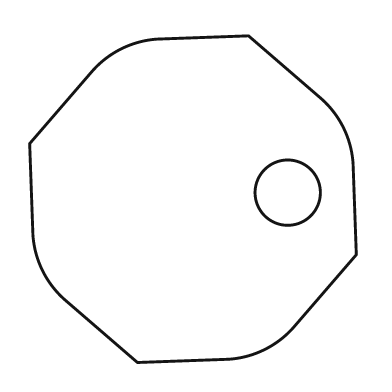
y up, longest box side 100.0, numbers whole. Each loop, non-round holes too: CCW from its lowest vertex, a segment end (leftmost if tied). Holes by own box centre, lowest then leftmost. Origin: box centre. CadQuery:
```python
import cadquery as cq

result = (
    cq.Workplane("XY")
    .moveTo(-17.0, -50.0)
    .lineTo(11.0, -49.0)
    .threePointArc((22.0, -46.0), (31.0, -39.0))
    .lineTo(50.0, -17.0)
    .lineTo(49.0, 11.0)
    .threePointArc((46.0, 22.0), (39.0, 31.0))
    .lineTo(17.0, 50.0)
    .lineTo(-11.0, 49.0)
    .threePointArc((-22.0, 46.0), (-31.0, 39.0))
    .lineTo(-50.0, 17.0)
    .lineTo(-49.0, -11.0)
    .threePointArc((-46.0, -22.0), (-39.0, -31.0))
    .close()
    .moveTo(29.0, 2.0)
    .circle(10.0)
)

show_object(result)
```